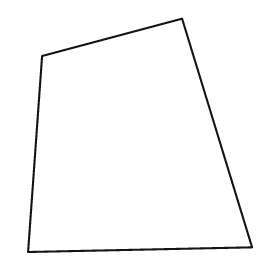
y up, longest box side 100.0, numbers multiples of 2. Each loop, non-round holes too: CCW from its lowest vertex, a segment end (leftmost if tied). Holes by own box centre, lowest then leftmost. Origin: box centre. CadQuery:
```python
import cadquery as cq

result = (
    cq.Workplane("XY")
    .moveTo(-48.0, -50.0)
    .lineTo(48.0, -48.0)
    .lineTo(18.0, 50.0)
    .lineTo(-42.0, 34.0)
    .close()
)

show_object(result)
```